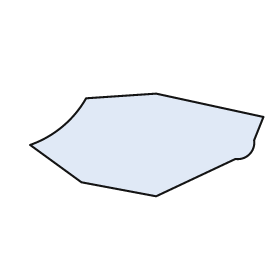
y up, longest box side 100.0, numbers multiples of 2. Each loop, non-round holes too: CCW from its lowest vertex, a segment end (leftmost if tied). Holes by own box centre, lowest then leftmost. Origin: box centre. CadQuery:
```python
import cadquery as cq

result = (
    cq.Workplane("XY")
    .moveTo(4.0, -22.0)
    .lineTo(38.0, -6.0)
    .threePointArc((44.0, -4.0), (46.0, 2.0))
    .lineTo(50.0, 12.0)
    .lineTo(4.0, 22.0)
    .lineTo(-26.0, 20.0)
    .threePointArc((-36.0, 8.0), (-50.0, 0.0))
    .lineTo(-28.0, -16.0)
    .close()
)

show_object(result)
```